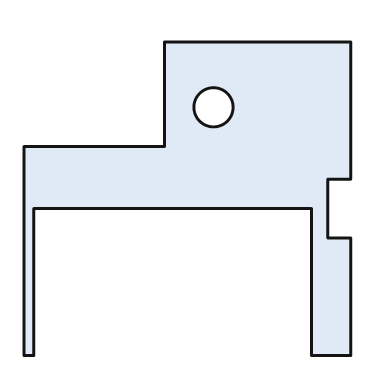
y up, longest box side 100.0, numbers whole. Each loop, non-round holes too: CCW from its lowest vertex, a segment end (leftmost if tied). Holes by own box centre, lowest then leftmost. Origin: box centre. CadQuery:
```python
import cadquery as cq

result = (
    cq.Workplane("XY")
    .moveTo(-50.0, -48.0)
    .lineTo(-47.0, -48.0)
    .lineTo(-47.0, -3.0)
    .lineTo(38.0, -3.0)
    .lineTo(38.0, -48.0)
    .lineTo(50.0, -48.0)
    .lineTo(50.0, -12.0)
    .lineTo(43.0, -12.0)
    .lineTo(43.0, 6.0)
    .lineTo(50.0, 6.0)
    .lineTo(50.0, 48.0)
    .lineTo(-7.0, 48.0)
    .lineTo(-7.0, 16.0)
    .lineTo(-50.0, 16.0)
    .close()
    .moveTo(8.0, 28.0)
    .circle(6.0)
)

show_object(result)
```